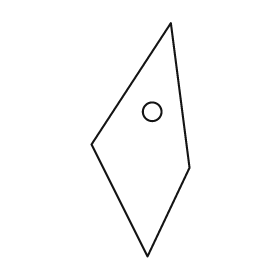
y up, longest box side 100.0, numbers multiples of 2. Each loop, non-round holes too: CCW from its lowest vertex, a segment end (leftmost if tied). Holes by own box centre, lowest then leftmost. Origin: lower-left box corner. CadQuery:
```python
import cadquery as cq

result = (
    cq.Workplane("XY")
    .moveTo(24.0, 0.0)
    .lineTo(42.0, 38.0)
    .lineTo(34.0, 100.0)
    .lineTo(0.0, 48.0)
    .close()
    .moveTo(26.0, 62.0)
    .circle(4.0)
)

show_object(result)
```